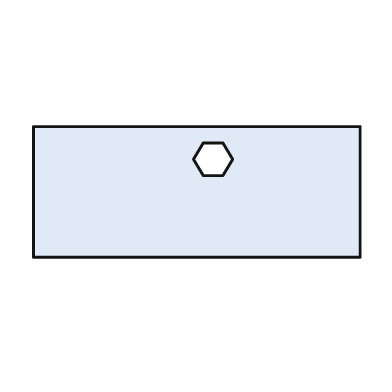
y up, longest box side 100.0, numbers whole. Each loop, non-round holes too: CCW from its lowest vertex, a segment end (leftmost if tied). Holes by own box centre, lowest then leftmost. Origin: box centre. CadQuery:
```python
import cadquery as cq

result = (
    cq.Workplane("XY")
    .moveTo(-50.0, -20.0)
    .lineTo(50.0, -20.0)
    .lineTo(50.0, 20.0)
    .lineTo(-50.0, 20.0)
    .close()
    .moveTo(2.0, 5.0)
    .lineTo(8.0, 5.0)
    .lineTo(11.0, 10.0)
    .lineTo(8.0, 15.0)
    .lineTo(2.0, 15.0)
    .lineTo(-1.0, 10.0)
    .close()
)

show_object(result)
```